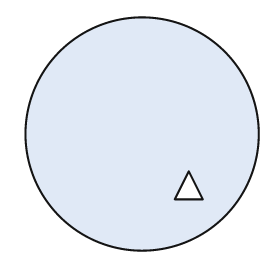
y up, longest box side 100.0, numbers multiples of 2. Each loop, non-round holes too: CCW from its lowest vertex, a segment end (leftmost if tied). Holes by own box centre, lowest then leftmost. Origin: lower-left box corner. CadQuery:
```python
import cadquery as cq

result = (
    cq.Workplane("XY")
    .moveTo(50.0, 50.0)
    .circle(50.0)
    .moveTo(64.0, 22.0)
    .lineTo(76.0, 22.0)
    .lineTo(70.0, 34.0)
    .close()
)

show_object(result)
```